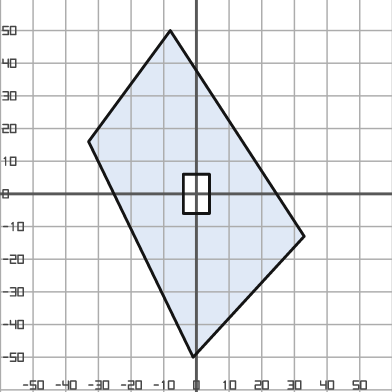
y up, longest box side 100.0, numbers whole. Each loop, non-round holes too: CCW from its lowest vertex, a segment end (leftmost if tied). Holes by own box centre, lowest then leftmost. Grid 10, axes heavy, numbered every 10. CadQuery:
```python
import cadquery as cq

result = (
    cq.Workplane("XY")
    .moveTo(-1.0, -50.0)
    .lineTo(33.0, -13.0)
    .lineTo(-8.0, 50.0)
    .lineTo(-33.0, 16.0)
    .close()
    .moveTo(-4.0, -6.0)
    .lineTo(4.0, -6.0)
    .lineTo(4.0, 6.0)
    .lineTo(-4.0, 6.0)
    .close()
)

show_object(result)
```